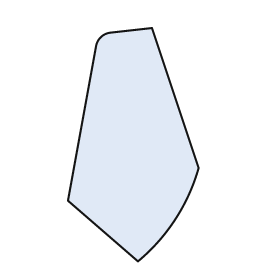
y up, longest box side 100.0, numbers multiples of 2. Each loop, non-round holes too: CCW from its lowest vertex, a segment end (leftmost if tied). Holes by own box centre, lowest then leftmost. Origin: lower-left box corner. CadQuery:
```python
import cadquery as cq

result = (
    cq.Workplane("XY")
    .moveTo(30.0, 0.0)
    .threePointArc((46.0, 18.0), (56.0, 40.0))
    .lineTo(36.0, 100.0)
    .lineTo(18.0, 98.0)
    .threePointArc((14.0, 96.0), (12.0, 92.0))
    .lineTo(0.0, 26.0)
    .close()
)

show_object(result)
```